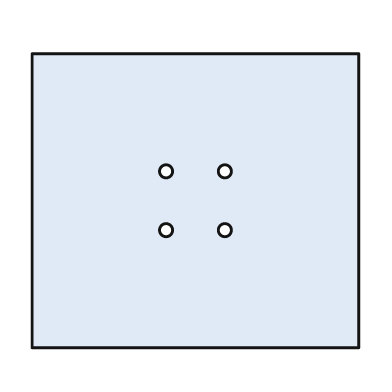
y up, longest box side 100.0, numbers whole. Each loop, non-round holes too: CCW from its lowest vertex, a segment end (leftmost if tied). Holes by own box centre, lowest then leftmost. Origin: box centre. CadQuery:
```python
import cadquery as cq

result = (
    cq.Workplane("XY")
    .moveTo(-50.0, -45.0)
    .lineTo(50.0, -45.0)
    .lineTo(50.0, 45.0)
    .lineTo(-50.0, 45.0)
    .close()
    .moveTo(-9.0, -9.0)
    .circle(2.0)
    .moveTo(9.0, -9.0)
    .circle(2.0)
    .moveTo(-9.0, 9.0)
    .circle(2.0)
    .moveTo(9.0, 9.0)
    .circle(2.0)
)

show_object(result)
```